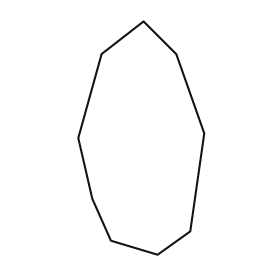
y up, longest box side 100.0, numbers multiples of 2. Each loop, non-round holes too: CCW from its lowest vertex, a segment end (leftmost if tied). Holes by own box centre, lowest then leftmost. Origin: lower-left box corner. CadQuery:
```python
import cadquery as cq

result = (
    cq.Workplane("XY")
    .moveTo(34.0, 0.0)
    .lineTo(48.0, 10.0)
    .lineTo(54.0, 52.0)
    .lineTo(42.0, 86.0)
    .lineTo(28.0, 100.0)
    .lineTo(10.0, 86.0)
    .lineTo(0.0, 50.0)
    .lineTo(6.0, 24.0)
    .lineTo(14.0, 6.0)
    .close()
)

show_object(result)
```